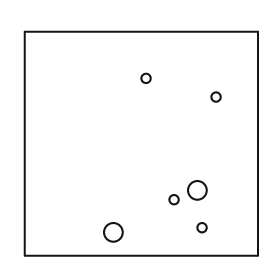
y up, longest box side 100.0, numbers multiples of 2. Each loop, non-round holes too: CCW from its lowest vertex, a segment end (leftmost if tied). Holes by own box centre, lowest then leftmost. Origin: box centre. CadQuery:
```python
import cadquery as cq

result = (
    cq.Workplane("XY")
    .moveTo(-50.0, -48.0)
    .lineTo(50.0, -48.0)
    .lineTo(50.0, 48.0)
    .lineTo(-50.0, 48.0)
    .close()
    .moveTo(-12.0, -38.0)
    .circle(4.0)
    .moveTo(26.0, -36.0)
    .circle(2.0)
    .moveTo(14.0, -24.0)
    .circle(2.0)
    .moveTo(24.0, -20.0)
    .circle(4.0)
    .moveTo(32.0, 20.0)
    .circle(2.0)
    .moveTo(2.0, 28.0)
    .circle(2.0)
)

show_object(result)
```